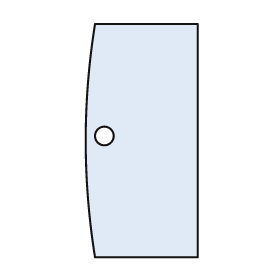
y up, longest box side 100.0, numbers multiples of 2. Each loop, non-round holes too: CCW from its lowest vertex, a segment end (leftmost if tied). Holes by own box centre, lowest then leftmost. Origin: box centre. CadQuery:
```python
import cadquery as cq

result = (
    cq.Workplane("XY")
    .moveTo(-20.0, -50.0)
    .lineTo(24.0, -50.0)
    .lineTo(24.0, 50.0)
    .lineTo(-20.0, 50.0)
    .threePointArc((-24.0, 0.0), (-20.0, -50.0))
    .close()
    .moveTo(-16.0, 2.0)
    .circle(4.0)
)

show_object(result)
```